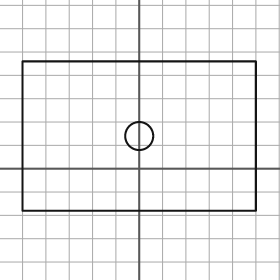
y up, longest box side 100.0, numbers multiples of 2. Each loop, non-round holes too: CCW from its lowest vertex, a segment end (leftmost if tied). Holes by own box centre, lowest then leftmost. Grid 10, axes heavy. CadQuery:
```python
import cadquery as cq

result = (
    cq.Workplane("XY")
    .moveTo(-50.0, -18.0)
    .lineTo(50.0, -18.0)
    .lineTo(50.0, 46.0)
    .lineTo(-50.0, 46.0)
    .close()
    .moveTo(0.0, 14.0)
    .circle(6.0)
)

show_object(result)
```